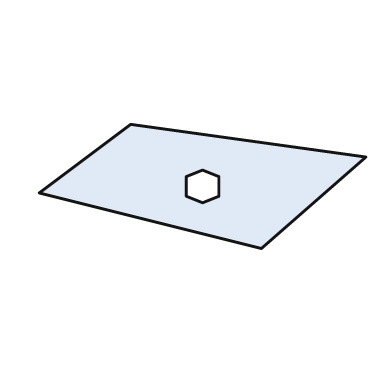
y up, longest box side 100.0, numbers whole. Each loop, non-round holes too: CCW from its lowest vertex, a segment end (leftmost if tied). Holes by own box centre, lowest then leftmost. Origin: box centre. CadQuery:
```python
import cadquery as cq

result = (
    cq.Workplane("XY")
    .moveTo(18.0, -19.0)
    .lineTo(50.0, 9.0)
    .lineTo(-22.0, 19.0)
    .lineTo(-50.0, -2.0)
    .close()
    .moveTo(0.0, -5.0)
    .lineTo(5.0, -3.0)
    .lineTo(5.0, 3.0)
    .lineTo(0.0, 5.0)
    .lineTo(-5.0, 3.0)
    .lineTo(-5.0, -3.0)
    .close()
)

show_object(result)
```